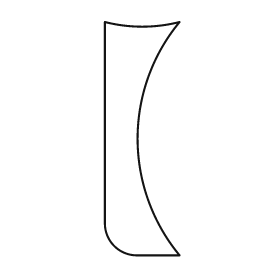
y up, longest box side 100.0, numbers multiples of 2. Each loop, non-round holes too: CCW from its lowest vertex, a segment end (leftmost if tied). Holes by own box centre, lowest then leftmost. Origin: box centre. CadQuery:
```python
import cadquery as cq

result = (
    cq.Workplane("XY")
    .moveTo(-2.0, -50.0)
    .lineTo(16.0, -50.0)
    .threePointArc((-2.0, 0.0), (16.0, 50.0))
    .threePointArc((0.0, 48.0), (-16.0, 50.0))
    .lineTo(-16.0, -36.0)
    .threePointArc((-12.0, -46.0), (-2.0, -50.0))
    .close()
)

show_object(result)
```